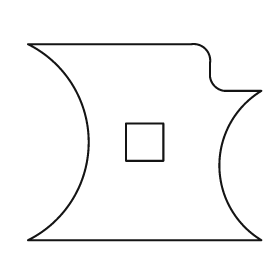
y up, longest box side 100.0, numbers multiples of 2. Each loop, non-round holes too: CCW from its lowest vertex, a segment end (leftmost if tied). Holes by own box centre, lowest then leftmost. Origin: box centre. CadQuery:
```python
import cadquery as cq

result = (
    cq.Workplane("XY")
    .moveTo(-50.0, -42.0)
    .lineTo(50.0, -42.0)
    .threePointArc((32.0, -10.0), (50.0, 22.0))
    .lineTo(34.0, 22.0)
    .threePointArc((30.0, 24.0), (28.0, 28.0))
    .lineTo(28.0, 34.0)
    .threePointArc((26.0, 40.0), (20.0, 42.0))
    .lineTo(-50.0, 42.0)
    .threePointArc((-24.0, 0.0), (-50.0, -42.0))
    .close()
    .moveTo(-8.0, -8.0)
    .lineTo(8.0, -8.0)
    .lineTo(8.0, 8.0)
    .lineTo(-8.0, 8.0)
    .close()
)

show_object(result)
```